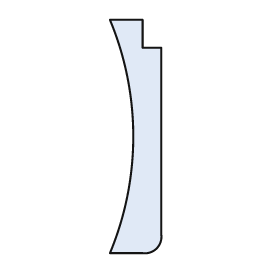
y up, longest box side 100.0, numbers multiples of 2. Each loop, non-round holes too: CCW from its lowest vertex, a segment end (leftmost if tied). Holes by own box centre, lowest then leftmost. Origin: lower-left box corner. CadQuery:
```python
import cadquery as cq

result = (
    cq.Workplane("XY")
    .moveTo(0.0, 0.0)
    .lineTo(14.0, 0.0)
    .threePointArc((20.0, 2.0), (22.0, 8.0))
    .lineTo(22.0, 88.0)
    .lineTo(14.0, 88.0)
    .lineTo(14.0, 100.0)
    .lineTo(0.0, 100.0)
    .threePointArc((10.0, 50.0), (0.0, 0.0))
    .close()
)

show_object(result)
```